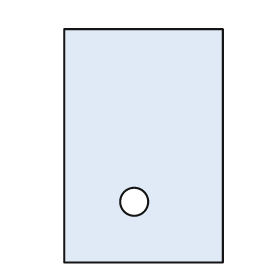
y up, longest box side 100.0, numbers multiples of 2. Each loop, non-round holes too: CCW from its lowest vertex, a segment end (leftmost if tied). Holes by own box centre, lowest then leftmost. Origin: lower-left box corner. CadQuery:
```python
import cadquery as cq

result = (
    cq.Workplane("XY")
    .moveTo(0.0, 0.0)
    .lineTo(68.0, 0.0)
    .lineTo(68.0, 100.0)
    .lineTo(0.0, 100.0)
    .close()
    .moveTo(30.0, 26.0)
    .circle(6.0)
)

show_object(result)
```